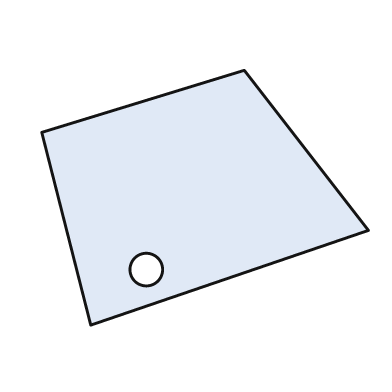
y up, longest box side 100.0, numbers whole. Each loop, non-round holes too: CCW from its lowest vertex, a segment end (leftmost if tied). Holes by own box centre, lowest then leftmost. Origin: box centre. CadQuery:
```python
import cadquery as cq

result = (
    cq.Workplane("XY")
    .moveTo(-35.0, -39.0)
    .lineTo(50.0, -10.0)
    .lineTo(12.0, 39.0)
    .lineTo(-50.0, 20.0)
    .close()
    .moveTo(-18.0, -22.0)
    .circle(5.0)
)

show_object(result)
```